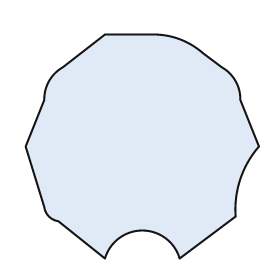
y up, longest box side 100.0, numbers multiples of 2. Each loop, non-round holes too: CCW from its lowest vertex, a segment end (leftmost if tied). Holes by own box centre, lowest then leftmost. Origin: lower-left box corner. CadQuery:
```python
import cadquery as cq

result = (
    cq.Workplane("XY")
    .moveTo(34.0, 0.0)
    .threePointArc((50.0, 12.0), (66.0, 0.0))
    .lineTo(90.0, 18.0)
    .threePointArc((92.0, 34.0), (100.0, 48.0))
    .lineTo(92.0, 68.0)
    .threePointArc((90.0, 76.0), (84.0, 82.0))
    .lineTo(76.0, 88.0)
    .threePointArc((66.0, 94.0), (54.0, 96.0))
    .lineTo(34.0, 96.0)
    .lineTo(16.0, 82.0)
    .threePointArc((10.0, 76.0), (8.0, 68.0))
    .lineTo(0.0, 48.0)
    .lineTo(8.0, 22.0)
    .threePointArc((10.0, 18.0), (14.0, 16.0))
    .close()
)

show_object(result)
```